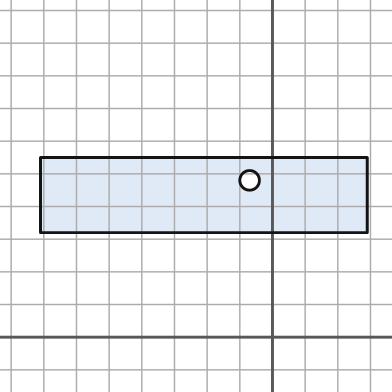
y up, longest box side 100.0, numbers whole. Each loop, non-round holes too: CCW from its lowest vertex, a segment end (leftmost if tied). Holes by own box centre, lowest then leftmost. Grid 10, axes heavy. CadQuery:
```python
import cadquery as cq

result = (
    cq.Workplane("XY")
    .moveTo(-71.0, 32.0)
    .lineTo(29.0, 32.0)
    .lineTo(29.0, 55.0)
    .lineTo(-71.0, 55.0)
    .close()
    .moveTo(-7.0, 48.0)
    .circle(3.0)
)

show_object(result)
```